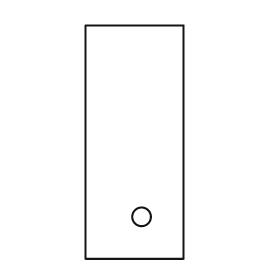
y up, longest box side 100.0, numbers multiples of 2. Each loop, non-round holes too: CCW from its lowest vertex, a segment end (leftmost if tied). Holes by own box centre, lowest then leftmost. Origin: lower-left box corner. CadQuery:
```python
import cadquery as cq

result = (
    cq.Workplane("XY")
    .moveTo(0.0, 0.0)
    .lineTo(42.0, 0.0)
    .lineTo(42.0, 100.0)
    .lineTo(0.0, 100.0)
    .close()
    .moveTo(24.0, 18.0)
    .circle(4.0)
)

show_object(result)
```